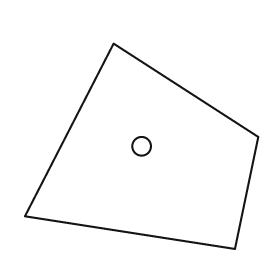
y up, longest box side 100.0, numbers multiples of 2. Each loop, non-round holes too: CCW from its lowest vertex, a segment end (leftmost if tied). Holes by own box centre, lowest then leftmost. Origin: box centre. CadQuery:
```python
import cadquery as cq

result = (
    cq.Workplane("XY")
    .moveTo(40.0, -44.0)
    .lineTo(50.0, 4.0)
    .lineTo(-12.0, 44.0)
    .lineTo(-50.0, -30.0)
    .close()
    .moveTo(0.0, 0.0)
    .circle(4.0)
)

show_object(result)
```